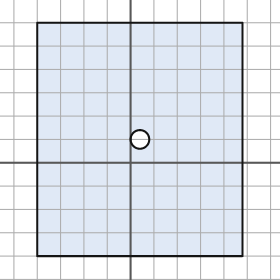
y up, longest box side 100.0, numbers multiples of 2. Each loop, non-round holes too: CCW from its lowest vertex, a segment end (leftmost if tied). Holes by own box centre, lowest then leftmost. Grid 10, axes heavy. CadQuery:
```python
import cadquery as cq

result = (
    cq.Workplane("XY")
    .moveTo(-40.0, -40.0)
    .lineTo(48.0, -40.0)
    .lineTo(48.0, 60.0)
    .lineTo(-40.0, 60.0)
    .close()
    .moveTo(4.0, 10.0)
    .circle(4.0)
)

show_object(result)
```